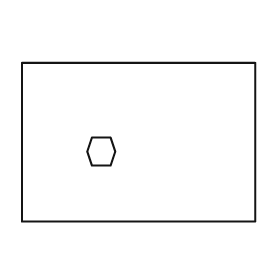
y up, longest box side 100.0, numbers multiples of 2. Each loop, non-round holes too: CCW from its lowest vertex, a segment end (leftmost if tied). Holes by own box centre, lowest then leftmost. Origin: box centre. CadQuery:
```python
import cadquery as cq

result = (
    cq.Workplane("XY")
    .moveTo(-50.0, -34.0)
    .lineTo(50.0, -34.0)
    .lineTo(50.0, 34.0)
    .lineTo(-50.0, 34.0)
    .close()
    .moveTo(-20.0, -10.0)
    .lineTo(-12.0, -10.0)
    .lineTo(-10.0, -4.0)
    .lineTo(-12.0, 2.0)
    .lineTo(-20.0, 2.0)
    .lineTo(-22.0, -4.0)
    .close()
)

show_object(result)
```